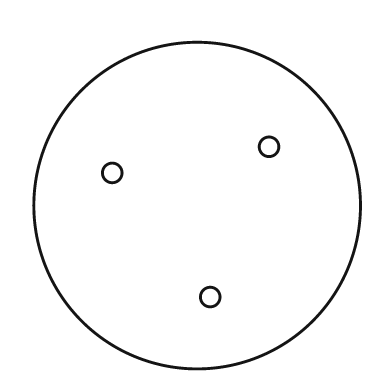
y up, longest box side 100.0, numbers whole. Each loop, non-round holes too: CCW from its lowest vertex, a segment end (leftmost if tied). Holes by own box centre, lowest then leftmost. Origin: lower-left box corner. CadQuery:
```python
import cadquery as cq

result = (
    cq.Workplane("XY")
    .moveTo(50.0, 50.0)
    .circle(50.0)
    .moveTo(54.0, 22.0)
    .circle(3.0)
    .moveTo(24.0, 60.0)
    .circle(3.0)
    .moveTo(72.0, 68.0)
    .circle(3.0)
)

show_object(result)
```